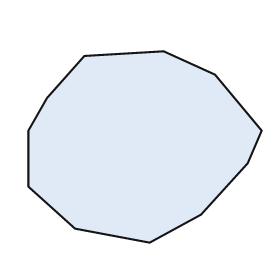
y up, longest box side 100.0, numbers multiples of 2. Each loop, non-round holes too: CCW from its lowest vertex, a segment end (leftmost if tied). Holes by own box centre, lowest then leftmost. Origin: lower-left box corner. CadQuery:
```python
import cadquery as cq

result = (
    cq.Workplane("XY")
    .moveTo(52.0, 0.0)
    .lineTo(74.0, 12.0)
    .lineTo(94.0, 34.0)
    .lineTo(100.0, 48.0)
    .lineTo(80.0, 72.0)
    .lineTo(58.0, 82.0)
    .lineTo(24.0, 80.0)
    .lineTo(8.0, 62.0)
    .lineTo(0.0, 48.0)
    .lineTo(0.0, 24.0)
    .lineTo(20.0, 6.0)
    .close()
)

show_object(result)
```